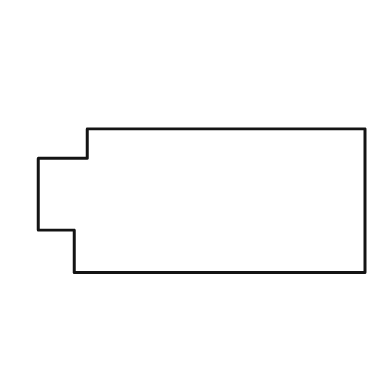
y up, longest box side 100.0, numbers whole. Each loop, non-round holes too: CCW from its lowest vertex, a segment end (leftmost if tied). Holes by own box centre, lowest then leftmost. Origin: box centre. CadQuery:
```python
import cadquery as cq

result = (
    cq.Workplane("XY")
    .moveTo(-39.0, -22.0)
    .lineTo(50.0, -22.0)
    .lineTo(50.0, 22.0)
    .lineTo(-35.0, 22.0)
    .lineTo(-35.0, 13.0)
    .lineTo(-50.0, 13.0)
    .lineTo(-50.0, -9.0)
    .lineTo(-39.0, -9.0)
    .close()
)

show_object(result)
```